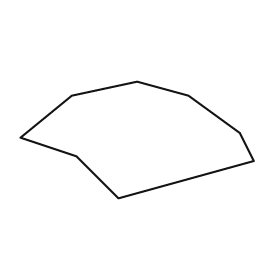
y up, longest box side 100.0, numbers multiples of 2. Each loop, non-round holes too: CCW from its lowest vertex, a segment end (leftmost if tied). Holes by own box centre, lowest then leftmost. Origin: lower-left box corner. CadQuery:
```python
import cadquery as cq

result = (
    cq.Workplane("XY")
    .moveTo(42.0, 0.0)
    .lineTo(100.0, 16.0)
    .lineTo(94.0, 28.0)
    .lineTo(72.0, 44.0)
    .lineTo(50.0, 50.0)
    .lineTo(22.0, 44.0)
    .lineTo(0.0, 26.0)
    .lineTo(24.0, 18.0)
    .close()
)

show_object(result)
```